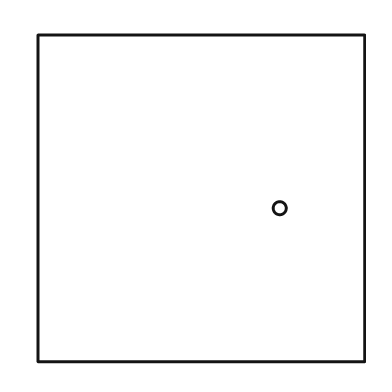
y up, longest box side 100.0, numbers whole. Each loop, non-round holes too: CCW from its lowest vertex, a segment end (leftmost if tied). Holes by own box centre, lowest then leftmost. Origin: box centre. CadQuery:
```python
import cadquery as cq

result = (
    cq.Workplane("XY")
    .moveTo(-50.0, -50.0)
    .lineTo(50.0, -50.0)
    .lineTo(50.0, 50.0)
    .lineTo(-50.0, 50.0)
    .close()
    .moveTo(24.0, -3.0)
    .circle(2.0)
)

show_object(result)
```